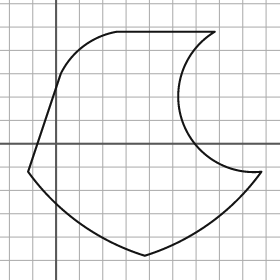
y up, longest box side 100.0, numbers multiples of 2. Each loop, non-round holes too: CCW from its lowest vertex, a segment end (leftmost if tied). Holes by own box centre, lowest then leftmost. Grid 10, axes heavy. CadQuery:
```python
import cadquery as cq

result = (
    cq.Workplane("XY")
    .moveTo(38.0, -48.0)
    .threePointArc((66.0, -34.0), (88.0, -12.0))
    .threePointArc((54.0, 10.0), (68.0, 48.0))
    .lineTo(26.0, 48.0)
    .threePointArc((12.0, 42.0), (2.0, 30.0))
    .lineTo(-12.0, -12.0)
    .threePointArc((10.0, -34.0), (38.0, -48.0))
    .close()
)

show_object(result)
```